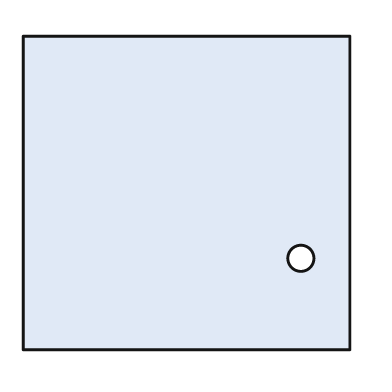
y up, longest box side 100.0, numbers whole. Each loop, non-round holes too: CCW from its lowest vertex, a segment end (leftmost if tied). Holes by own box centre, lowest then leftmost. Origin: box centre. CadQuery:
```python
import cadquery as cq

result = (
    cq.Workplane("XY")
    .moveTo(-50.0, -48.0)
    .lineTo(50.0, -48.0)
    .lineTo(50.0, 48.0)
    .lineTo(-50.0, 48.0)
    .close()
    .moveTo(35.0, -20.0)
    .circle(4.0)
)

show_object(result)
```